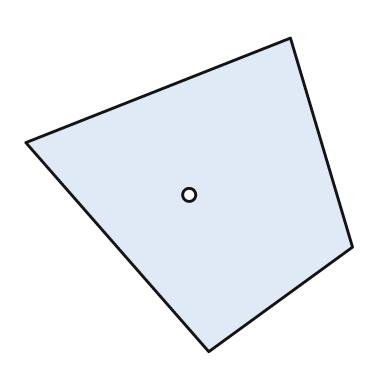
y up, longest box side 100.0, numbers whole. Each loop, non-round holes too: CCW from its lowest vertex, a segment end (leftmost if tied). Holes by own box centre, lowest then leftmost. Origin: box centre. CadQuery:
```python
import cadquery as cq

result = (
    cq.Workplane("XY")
    .moveTo(6.0, -48.0)
    .lineTo(50.0, -16.0)
    .lineTo(31.0, 48.0)
    .lineTo(-50.0, 16.0)
    .close()
    .moveTo(0.0, 0.0)
    .circle(2.0)
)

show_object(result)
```